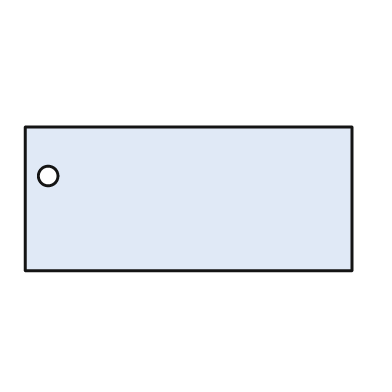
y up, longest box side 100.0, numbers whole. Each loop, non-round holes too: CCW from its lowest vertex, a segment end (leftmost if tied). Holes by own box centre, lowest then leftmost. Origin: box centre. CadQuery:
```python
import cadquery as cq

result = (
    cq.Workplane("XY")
    .moveTo(-50.0, -22.0)
    .lineTo(50.0, -22.0)
    .lineTo(50.0, 22.0)
    .lineTo(-50.0, 22.0)
    .close()
    .moveTo(-43.0, 7.0)
    .circle(3.0)
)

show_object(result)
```